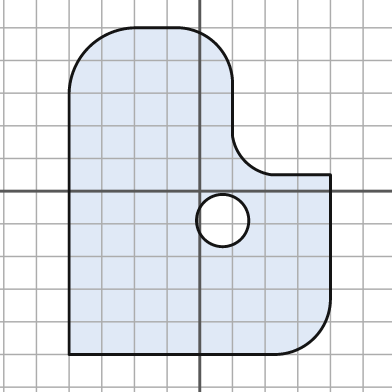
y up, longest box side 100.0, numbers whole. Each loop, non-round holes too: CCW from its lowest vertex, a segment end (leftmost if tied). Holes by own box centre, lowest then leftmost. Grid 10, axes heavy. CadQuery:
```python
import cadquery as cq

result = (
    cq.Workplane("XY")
    .moveTo(-40.0, -50.0)
    .lineTo(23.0, -50.0)
    .threePointArc((35.0, -45.0), (40.0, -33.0))
    .lineTo(40.0, 5.0)
    .lineTo(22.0, 5.0)
    .threePointArc((14.0, 9.0), (10.0, 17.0))
    .lineTo(10.0, 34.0)
    .threePointArc((5.0, 45.0), (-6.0, 50.0))
    .lineTo(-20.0, 50.0)
    .threePointArc((-34.0, 44.0), (-40.0, 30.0))
    .close()
    .moveTo(7.0, -9.0)
    .circle(8.0)
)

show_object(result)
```